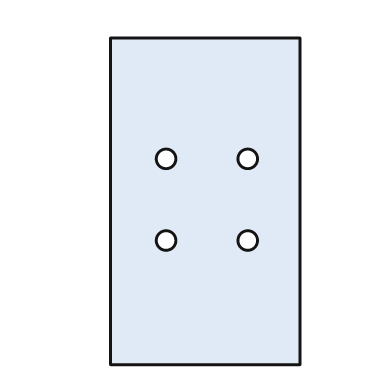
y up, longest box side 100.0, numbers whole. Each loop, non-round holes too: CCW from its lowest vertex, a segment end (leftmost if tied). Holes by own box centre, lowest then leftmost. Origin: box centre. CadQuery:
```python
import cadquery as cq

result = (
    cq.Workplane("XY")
    .moveTo(-29.0, -50.0)
    .lineTo(29.0, -50.0)
    .lineTo(29.0, 50.0)
    .lineTo(-29.0, 50.0)
    .close()
    .moveTo(-12.0, -12.0)
    .circle(3.0)
    .moveTo(13.0, -12.0)
    .circle(3.0)
    .moveTo(-12.0, 13.0)
    .circle(3.0)
    .moveTo(13.0, 13.0)
    .circle(3.0)
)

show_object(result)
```